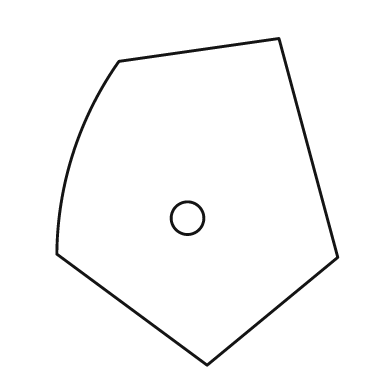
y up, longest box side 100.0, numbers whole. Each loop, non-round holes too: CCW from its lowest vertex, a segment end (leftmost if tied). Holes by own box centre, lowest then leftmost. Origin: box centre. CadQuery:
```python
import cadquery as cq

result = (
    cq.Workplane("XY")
    .moveTo(3.0, -50.0)
    .lineTo(43.0, -17.0)
    .lineTo(25.0, 50.0)
    .lineTo(-24.0, 43.0)
    .threePointArc((-38.0, 15.0), (-43.0, -16.0))
    .close()
    .moveTo(-3.0, -5.0)
    .circle(5.0)
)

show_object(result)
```